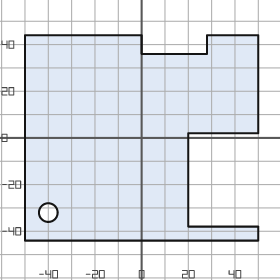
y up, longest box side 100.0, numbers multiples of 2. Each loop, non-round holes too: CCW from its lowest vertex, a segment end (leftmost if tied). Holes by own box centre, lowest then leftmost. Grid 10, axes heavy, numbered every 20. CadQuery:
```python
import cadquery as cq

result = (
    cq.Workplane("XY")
    .moveTo(-50.0, -44.0)
    .lineTo(50.0, -44.0)
    .lineTo(50.0, -38.0)
    .lineTo(20.0, -38.0)
    .lineTo(20.0, 2.0)
    .lineTo(50.0, 2.0)
    .lineTo(50.0, 44.0)
    .lineTo(28.0, 44.0)
    .lineTo(28.0, 36.0)
    .lineTo(0.0, 36.0)
    .lineTo(0.0, 44.0)
    .lineTo(-50.0, 44.0)
    .close()
    .moveTo(-40.0, -32.0)
    .circle(4.0)
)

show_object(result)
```